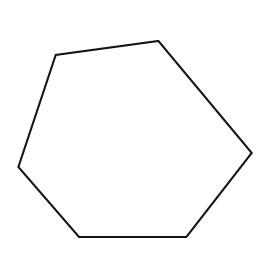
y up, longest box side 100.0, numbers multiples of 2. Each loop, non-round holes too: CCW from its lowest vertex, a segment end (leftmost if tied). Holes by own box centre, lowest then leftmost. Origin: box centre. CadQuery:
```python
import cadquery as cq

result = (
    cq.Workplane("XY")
    .moveTo(-24.0, -42.0)
    .lineTo(22.0, -42.0)
    .lineTo(50.0, -6.0)
    .lineTo(10.0, 42.0)
    .lineTo(-34.0, 36.0)
    .lineTo(-50.0, -12.0)
    .close()
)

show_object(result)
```